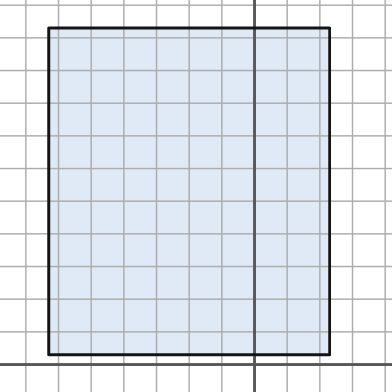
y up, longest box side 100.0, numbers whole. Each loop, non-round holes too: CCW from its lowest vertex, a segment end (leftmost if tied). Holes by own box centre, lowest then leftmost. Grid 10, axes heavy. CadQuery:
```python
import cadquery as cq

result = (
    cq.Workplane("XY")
    .moveTo(-63.0, 3.0)
    .lineTo(23.0, 3.0)
    .lineTo(23.0, 103.0)
    .lineTo(-63.0, 103.0)
    .close()
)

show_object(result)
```